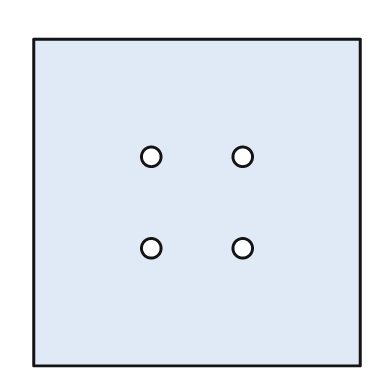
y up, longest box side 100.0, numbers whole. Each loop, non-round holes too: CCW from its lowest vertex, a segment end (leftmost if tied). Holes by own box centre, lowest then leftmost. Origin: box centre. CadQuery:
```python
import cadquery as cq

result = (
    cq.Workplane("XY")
    .moveTo(-50.0, -50.0)
    .lineTo(50.0, -50.0)
    .lineTo(50.0, 50.0)
    .lineTo(-50.0, 50.0)
    .close()
    .moveTo(-14.0, -14.0)
    .circle(3.0)
    .moveTo(14.0, -14.0)
    .circle(3.0)
    .moveTo(-14.0, 14.0)
    .circle(3.0)
    .moveTo(14.0, 14.0)
    .circle(3.0)
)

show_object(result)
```